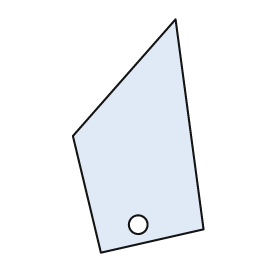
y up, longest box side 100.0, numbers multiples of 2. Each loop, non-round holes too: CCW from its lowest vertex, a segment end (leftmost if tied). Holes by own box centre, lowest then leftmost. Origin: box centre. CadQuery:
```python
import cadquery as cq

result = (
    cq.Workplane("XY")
    .moveTo(-16.0, -50.0)
    .lineTo(28.0, -40.0)
    .lineTo(16.0, 50.0)
    .lineTo(-28.0, 0.0)
    .close()
    .moveTo(0.0, -38.0)
    .circle(4.0)
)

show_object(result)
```